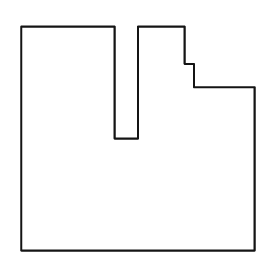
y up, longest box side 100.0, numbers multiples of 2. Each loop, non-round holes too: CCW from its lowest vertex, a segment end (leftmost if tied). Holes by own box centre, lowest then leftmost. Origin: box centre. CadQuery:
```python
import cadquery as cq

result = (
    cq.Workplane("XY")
    .moveTo(-50.0, -48.0)
    .lineTo(50.0, -48.0)
    .lineTo(50.0, 22.0)
    .lineTo(24.0, 22.0)
    .lineTo(24.0, 32.0)
    .lineTo(20.0, 32.0)
    .lineTo(20.0, 48.0)
    .lineTo(0.0, 48.0)
    .lineTo(0.0, 0.0)
    .lineTo(-10.0, 0.0)
    .lineTo(-10.0, 48.0)
    .lineTo(-50.0, 48.0)
    .close()
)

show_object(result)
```